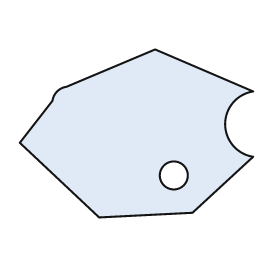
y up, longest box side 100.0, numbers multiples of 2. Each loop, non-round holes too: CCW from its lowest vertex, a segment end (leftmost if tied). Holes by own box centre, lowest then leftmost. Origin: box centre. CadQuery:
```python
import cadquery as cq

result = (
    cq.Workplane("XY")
    .moveTo(-16.0, -36.0)
    .lineTo(24.0, -34.0)
    .lineTo(50.0, -10.0)
    .threePointArc((38.0, 4.0), (50.0, 18.0))
    .lineTo(8.0, 36.0)
    .lineTo(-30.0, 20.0)
    .threePointArc((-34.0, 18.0), (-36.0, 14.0))
    .lineTo(-50.0, -4.0)
    .close()
    .moveTo(16.0, -18.0)
    .circle(6.0)
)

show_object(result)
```